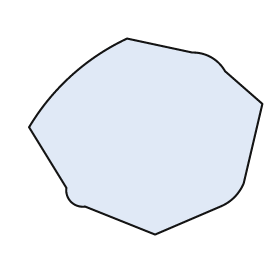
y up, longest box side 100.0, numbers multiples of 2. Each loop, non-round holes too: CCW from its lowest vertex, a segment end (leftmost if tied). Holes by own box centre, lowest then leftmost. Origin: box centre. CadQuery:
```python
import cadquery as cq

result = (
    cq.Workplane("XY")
    .moveTo(4.0, -42.0)
    .lineTo(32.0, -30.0)
    .threePointArc((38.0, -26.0), (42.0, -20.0))
    .lineTo(50.0, 14.0)
    .lineTo(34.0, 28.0)
    .threePointArc((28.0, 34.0), (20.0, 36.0))
    .lineTo(-8.0, 42.0)
    .threePointArc((-32.0, 26.0), (-50.0, 4.0))
    .lineTo(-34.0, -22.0)
    .threePointArc((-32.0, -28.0), (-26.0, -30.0))
    .close()
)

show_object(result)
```